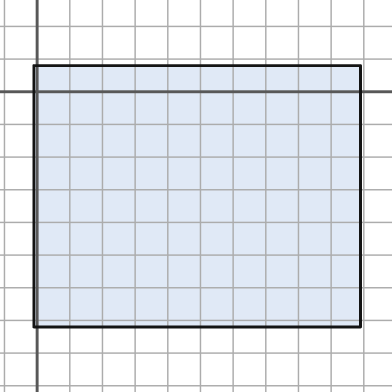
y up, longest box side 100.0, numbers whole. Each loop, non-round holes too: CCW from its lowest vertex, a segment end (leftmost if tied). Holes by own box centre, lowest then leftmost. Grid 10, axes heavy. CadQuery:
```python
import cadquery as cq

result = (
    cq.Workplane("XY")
    .moveTo(-1.0, -72.0)
    .lineTo(99.0, -72.0)
    .lineTo(99.0, 8.0)
    .lineTo(-1.0, 8.0)
    .close()
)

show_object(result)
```